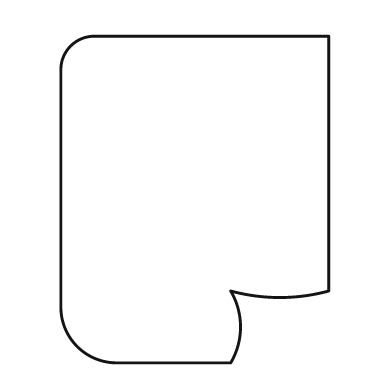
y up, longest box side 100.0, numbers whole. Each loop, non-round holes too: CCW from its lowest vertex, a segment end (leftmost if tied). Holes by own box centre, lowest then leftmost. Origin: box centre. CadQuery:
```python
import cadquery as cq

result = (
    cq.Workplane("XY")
    .moveTo(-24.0, -50.0)
    .lineTo(11.0, -50.0)
    .threePointArc((14.0, -39.0), (11.0, -28.0))
    .threePointArc((26.0, -30.0), (41.0, -28.0))
    .lineTo(41.0, 50.0)
    .lineTo(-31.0, 50.0)
    .threePointArc((-38.0, 47.0), (-41.0, 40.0))
    .lineTo(-41.0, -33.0)
    .threePointArc((-36.0, -45.0), (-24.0, -50.0))
    .close()
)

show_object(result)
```